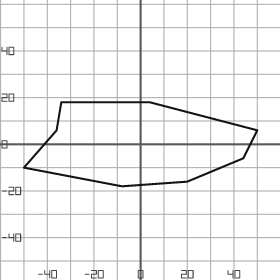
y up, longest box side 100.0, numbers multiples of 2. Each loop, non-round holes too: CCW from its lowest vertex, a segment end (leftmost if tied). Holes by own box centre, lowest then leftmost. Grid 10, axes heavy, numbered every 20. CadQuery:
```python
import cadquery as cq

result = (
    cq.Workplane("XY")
    .moveTo(-8.0, -18.0)
    .lineTo(20.0, -16.0)
    .lineTo(44.0, -6.0)
    .lineTo(50.0, 6.0)
    .lineTo(4.0, 18.0)
    .lineTo(-34.0, 18.0)
    .lineTo(-36.0, 6.0)
    .lineTo(-50.0, -10.0)
    .close()
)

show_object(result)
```